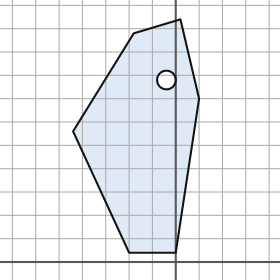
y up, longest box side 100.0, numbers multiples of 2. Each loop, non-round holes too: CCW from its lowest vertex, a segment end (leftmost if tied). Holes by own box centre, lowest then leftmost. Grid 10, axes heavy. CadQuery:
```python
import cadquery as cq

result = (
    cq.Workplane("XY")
    .moveTo(-20.0, 4.0)
    .lineTo(0.0, 4.0)
    .lineTo(10.0, 70.0)
    .lineTo(2.0, 104.0)
    .lineTo(-18.0, 98.0)
    .lineTo(-44.0, 56.0)
    .close()
    .moveTo(-4.0, 78.0)
    .circle(4.0)
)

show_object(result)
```